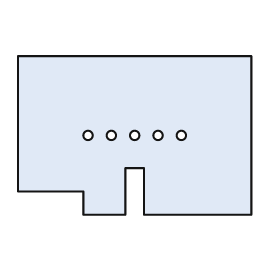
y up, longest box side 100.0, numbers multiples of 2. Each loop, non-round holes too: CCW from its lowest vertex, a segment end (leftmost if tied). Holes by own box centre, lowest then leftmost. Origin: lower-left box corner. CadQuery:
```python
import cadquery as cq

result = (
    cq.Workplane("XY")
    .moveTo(28.0, 0.0)
    .lineTo(46.0, 0.0)
    .lineTo(46.0, 20.0)
    .lineTo(54.0, 20.0)
    .lineTo(54.0, 0.0)
    .lineTo(100.0, 0.0)
    .lineTo(100.0, 68.0)
    .lineTo(0.0, 68.0)
    .lineTo(0.0, 10.0)
    .lineTo(28.0, 10.0)
    .close()
    .moveTo(30.0, 34.0)
    .circle(2.0)
    .moveTo(40.0, 34.0)
    .circle(2.0)
    .moveTo(50.0, 34.0)
    .circle(2.0)
    .moveTo(60.0, 34.0)
    .circle(2.0)
    .moveTo(70.0, 34.0)
    .circle(2.0)
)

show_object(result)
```